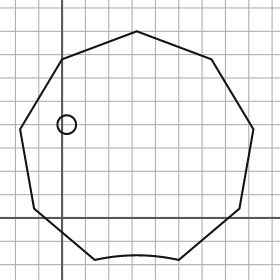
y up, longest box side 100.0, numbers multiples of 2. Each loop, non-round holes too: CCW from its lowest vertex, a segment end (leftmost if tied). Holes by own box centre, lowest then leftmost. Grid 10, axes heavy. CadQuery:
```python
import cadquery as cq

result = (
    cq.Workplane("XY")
    .moveTo(14.0, -18.0)
    .threePointArc((32.0, -16.0), (50.0, -18.0))
    .lineTo(76.0, 4.0)
    .lineTo(82.0, 38.0)
    .lineTo(64.0, 68.0)
    .lineTo(32.0, 80.0)
    .lineTo(0.0, 68.0)
    .lineTo(-18.0, 38.0)
    .lineTo(-12.0, 4.0)
    .close()
    .moveTo(2.0, 40.0)
    .circle(4.0)
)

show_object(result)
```